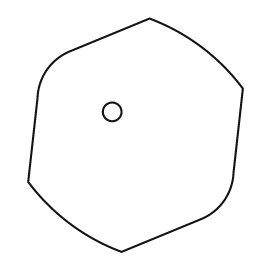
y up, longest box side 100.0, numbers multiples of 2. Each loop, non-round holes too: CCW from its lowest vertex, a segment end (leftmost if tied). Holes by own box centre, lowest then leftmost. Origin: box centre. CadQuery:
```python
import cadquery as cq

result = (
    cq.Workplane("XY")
    .moveTo(-6.0, -50.0)
    .lineTo(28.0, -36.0)
    .threePointArc((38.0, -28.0), (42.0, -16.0))
    .lineTo(46.0, 20.0)
    .threePointArc((28.0, 38.0), (6.0, 50.0))
    .lineTo(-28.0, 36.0)
    .threePointArc((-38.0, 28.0), (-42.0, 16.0))
    .lineTo(-46.0, -20.0)
    .threePointArc((-28.0, -38.0), (-6.0, -50.0))
    .close()
    .moveTo(-10.0, 10.0)
    .circle(4.0)
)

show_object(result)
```